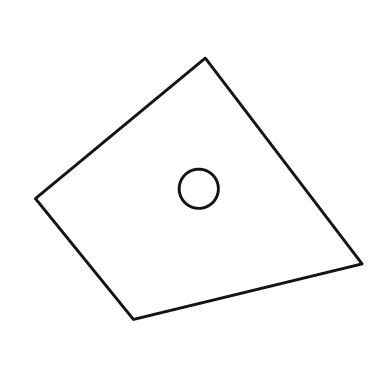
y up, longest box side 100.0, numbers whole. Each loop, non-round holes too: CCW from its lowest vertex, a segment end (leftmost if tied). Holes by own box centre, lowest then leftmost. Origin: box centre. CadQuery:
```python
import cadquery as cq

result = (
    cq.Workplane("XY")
    .moveTo(-20.0, -40.0)
    .lineTo(50.0, -23.0)
    .lineTo(2.0, 40.0)
    .lineTo(-50.0, -3.0)
    .close()
    .moveTo(0.0, 0.0)
    .circle(6.0)
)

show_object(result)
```